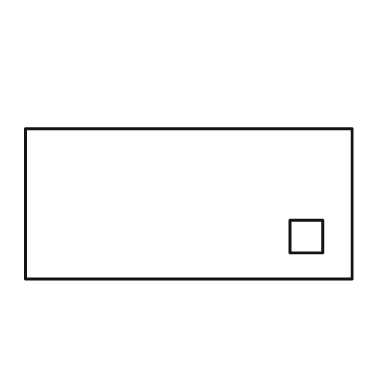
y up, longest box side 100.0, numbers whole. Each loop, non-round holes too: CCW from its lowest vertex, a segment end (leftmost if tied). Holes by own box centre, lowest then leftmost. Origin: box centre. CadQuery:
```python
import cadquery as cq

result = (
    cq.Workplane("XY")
    .moveTo(-50.0, -23.0)
    .lineTo(50.0, -23.0)
    .lineTo(50.0, 23.0)
    .lineTo(-50.0, 23.0)
    .close()
    .moveTo(31.0, -15.0)
    .lineTo(41.0, -15.0)
    .lineTo(41.0, -5.0)
    .lineTo(31.0, -5.0)
    .close()
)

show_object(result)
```